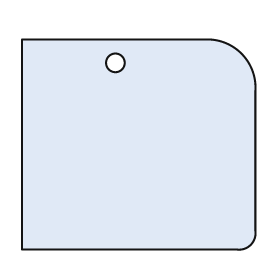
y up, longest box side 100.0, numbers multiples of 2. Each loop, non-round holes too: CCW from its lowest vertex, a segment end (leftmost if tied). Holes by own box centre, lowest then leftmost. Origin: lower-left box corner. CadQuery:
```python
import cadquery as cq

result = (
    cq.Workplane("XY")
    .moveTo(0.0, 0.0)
    .lineTo(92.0, 0.0)
    .threePointArc((98.0, 2.0), (100.0, 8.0))
    .lineTo(100.0, 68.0)
    .threePointArc((94.0, 84.0), (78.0, 90.0))
    .lineTo(0.0, 90.0)
    .close()
    .moveTo(40.0, 80.0)
    .circle(4.0)
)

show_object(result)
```